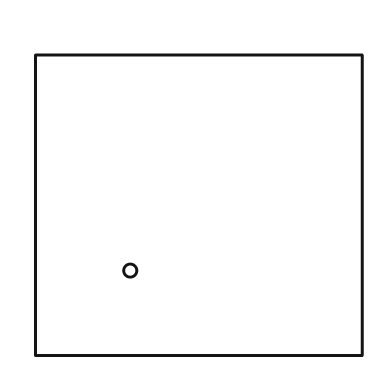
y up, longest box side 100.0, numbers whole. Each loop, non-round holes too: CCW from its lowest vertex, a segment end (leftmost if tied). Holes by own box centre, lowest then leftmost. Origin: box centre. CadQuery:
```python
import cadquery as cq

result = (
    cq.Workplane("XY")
    .moveTo(-50.0, -46.0)
    .lineTo(50.0, -46.0)
    .lineTo(50.0, 46.0)
    .lineTo(-50.0, 46.0)
    .close()
    .moveTo(-21.0, -20.0)
    .circle(2.0)
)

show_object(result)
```